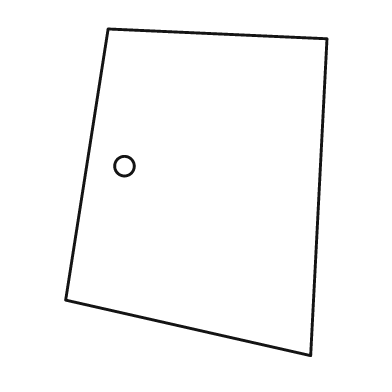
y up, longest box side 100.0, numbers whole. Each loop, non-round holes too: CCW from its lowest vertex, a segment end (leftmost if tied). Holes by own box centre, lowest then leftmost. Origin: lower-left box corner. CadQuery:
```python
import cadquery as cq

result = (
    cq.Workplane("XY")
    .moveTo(75.0, 0.0)
    .lineTo(80.0, 97.0)
    .lineTo(13.0, 100.0)
    .lineTo(0.0, 17.0)
    .close()
    .moveTo(18.0, 58.0)
    .circle(3.0)
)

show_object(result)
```